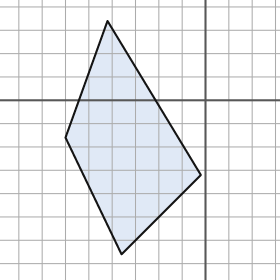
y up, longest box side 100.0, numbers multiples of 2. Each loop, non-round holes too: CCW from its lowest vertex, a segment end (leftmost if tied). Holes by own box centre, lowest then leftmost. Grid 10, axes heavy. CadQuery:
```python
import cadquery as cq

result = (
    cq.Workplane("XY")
    .moveTo(-36.0, -66.0)
    .lineTo(-2.0, -32.0)
    .lineTo(-42.0, 34.0)
    .lineTo(-60.0, -16.0)
    .close()
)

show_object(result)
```